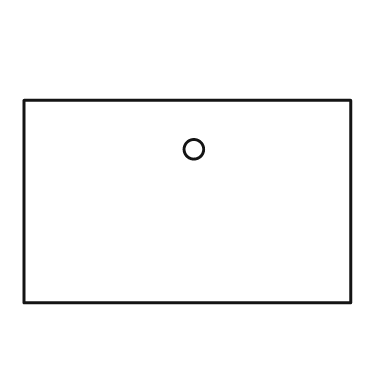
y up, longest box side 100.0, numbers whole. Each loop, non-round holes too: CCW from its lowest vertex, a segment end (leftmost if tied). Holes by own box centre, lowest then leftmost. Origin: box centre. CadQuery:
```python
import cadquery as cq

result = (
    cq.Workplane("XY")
    .moveTo(-50.0, -31.0)
    .lineTo(50.0, -31.0)
    .lineTo(50.0, 31.0)
    .lineTo(-50.0, 31.0)
    .close()
    .moveTo(2.0, 16.0)
    .circle(3.0)
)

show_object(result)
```